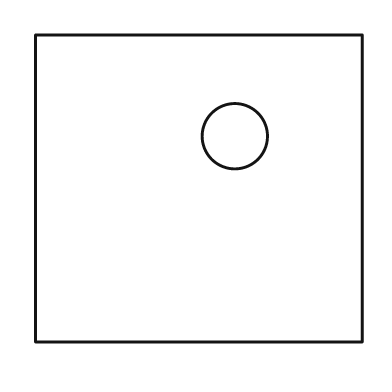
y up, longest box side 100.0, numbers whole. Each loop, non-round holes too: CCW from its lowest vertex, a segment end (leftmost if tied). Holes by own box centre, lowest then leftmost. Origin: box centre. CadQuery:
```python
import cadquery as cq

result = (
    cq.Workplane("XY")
    .moveTo(-50.0, -47.0)
    .lineTo(50.0, -47.0)
    .lineTo(50.0, 47.0)
    .lineTo(-50.0, 47.0)
    .close()
    .moveTo(11.0, 16.0)
    .circle(10.0)
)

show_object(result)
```